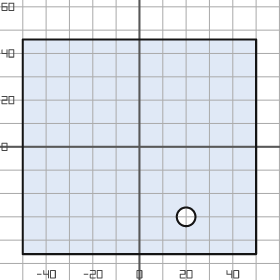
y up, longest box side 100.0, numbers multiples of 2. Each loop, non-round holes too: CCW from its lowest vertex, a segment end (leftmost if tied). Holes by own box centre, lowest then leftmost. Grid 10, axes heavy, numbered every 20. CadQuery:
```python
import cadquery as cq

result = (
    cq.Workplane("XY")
    .moveTo(-50.0, -46.0)
    .lineTo(50.0, -46.0)
    .lineTo(50.0, 46.0)
    .lineTo(-50.0, 46.0)
    .close()
    .moveTo(20.0, -30.0)
    .circle(4.0)
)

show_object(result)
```